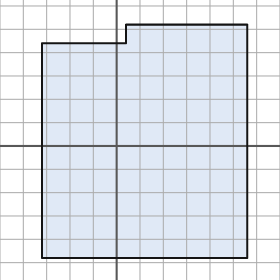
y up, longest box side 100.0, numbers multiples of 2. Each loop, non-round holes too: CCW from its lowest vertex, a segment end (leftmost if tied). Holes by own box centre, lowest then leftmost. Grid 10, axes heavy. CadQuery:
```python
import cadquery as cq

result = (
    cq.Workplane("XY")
    .moveTo(-32.0, -48.0)
    .lineTo(56.0, -48.0)
    .lineTo(56.0, 52.0)
    .lineTo(4.0, 52.0)
    .lineTo(4.0, 44.0)
    .lineTo(-32.0, 44.0)
    .close()
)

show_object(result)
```